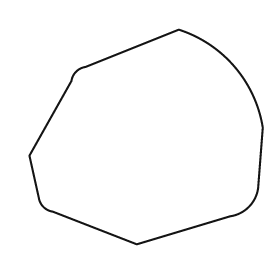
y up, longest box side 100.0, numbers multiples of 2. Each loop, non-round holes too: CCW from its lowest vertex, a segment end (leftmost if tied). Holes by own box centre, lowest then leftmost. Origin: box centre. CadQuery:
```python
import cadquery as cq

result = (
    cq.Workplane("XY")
    .moveTo(-4.0, -46.0)
    .lineTo(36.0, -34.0)
    .threePointArc((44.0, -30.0), (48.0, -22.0))
    .lineTo(50.0, 4.0)
    .threePointArc((38.0, 30.0), (14.0, 46.0))
    .lineTo(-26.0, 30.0)
    .threePointArc((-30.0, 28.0), (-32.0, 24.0))
    .lineTo(-50.0, -8.0)
    .lineTo(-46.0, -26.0)
    .threePointArc((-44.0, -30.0), (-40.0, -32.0))
    .close()
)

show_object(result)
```